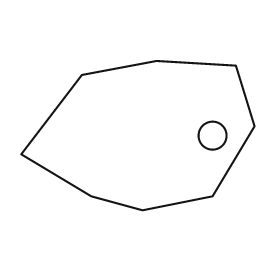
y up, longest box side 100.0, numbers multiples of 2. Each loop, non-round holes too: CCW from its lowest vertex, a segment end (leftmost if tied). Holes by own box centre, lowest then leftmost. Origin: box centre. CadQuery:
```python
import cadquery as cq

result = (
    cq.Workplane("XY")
    .moveTo(2.0, -32.0)
    .lineTo(32.0, -26.0)
    .lineTo(50.0, 4.0)
    .lineTo(42.0, 30.0)
    .lineTo(8.0, 32.0)
    .lineTo(-24.0, 26.0)
    .lineTo(-50.0, -8.0)
    .lineTo(-20.0, -26.0)
    .close()
    .moveTo(32.0, 0.0)
    .circle(6.0)
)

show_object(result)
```